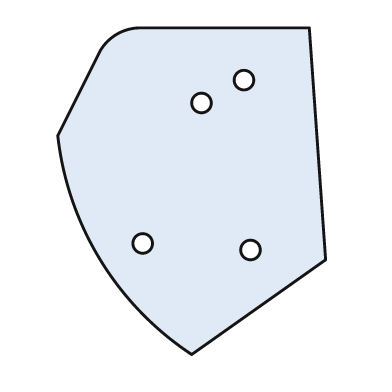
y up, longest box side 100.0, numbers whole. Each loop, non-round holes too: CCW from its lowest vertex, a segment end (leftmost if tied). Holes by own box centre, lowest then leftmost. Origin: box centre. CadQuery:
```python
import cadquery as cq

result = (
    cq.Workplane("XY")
    .moveTo(0.0, -50.0)
    .lineTo(41.0, -21.0)
    .lineTo(36.0, 50.0)
    .lineTo(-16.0, 50.0)
    .threePointArc((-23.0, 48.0), (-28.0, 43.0))
    .lineTo(-41.0, 17.0)
    .threePointArc((-28.0, -21.0), (0.0, -50.0))
    .close()
    .moveTo(18.0, -18.0)
    .circle(3.0)
    .moveTo(-15.0, -16.0)
    .circle(3.0)
    .moveTo(3.0, 27.0)
    .circle(3.0)
    .moveTo(16.0, 34.0)
    .circle(3.0)
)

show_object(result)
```